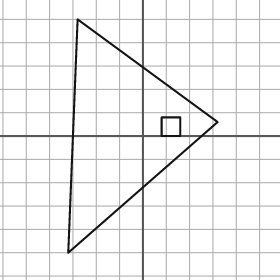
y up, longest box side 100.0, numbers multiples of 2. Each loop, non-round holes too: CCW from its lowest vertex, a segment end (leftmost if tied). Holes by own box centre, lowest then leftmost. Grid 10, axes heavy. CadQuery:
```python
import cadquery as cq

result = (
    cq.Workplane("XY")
    .moveTo(-32.0, -50.0)
    .lineTo(32.0, 6.0)
    .lineTo(-28.0, 50.0)
    .close()
    .moveTo(8.0, 0.0)
    .lineTo(16.0, 0.0)
    .lineTo(16.0, 8.0)
    .lineTo(8.0, 8.0)
    .close()
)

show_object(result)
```